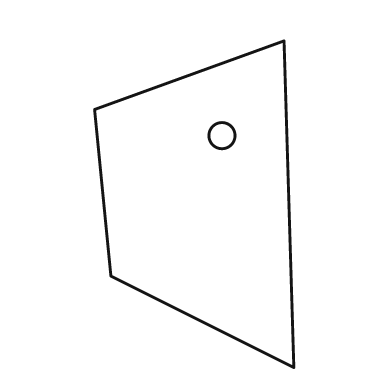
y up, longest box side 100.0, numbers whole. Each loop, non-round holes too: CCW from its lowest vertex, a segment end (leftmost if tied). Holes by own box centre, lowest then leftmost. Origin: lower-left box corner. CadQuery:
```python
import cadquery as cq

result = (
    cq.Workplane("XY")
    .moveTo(61.0, 0.0)
    .lineTo(58.0, 100.0)
    .lineTo(0.0, 79.0)
    .lineTo(5.0, 28.0)
    .close()
    .moveTo(39.0, 71.0)
    .circle(4.0)
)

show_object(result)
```